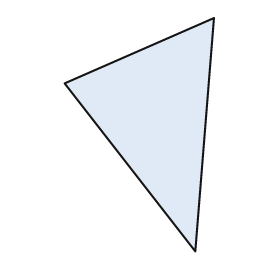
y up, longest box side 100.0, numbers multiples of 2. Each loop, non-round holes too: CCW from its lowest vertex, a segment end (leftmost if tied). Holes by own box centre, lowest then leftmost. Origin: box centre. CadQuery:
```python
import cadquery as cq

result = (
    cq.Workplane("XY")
    .moveTo(24.0, -50.0)
    .lineTo(32.0, 50.0)
    .lineTo(-32.0, 22.0)
    .close()
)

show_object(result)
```